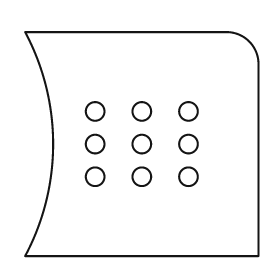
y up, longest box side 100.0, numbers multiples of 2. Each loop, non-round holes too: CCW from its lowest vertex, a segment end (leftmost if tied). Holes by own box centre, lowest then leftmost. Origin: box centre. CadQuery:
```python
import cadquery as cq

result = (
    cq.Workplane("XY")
    .moveTo(-50.0, -48.0)
    .lineTo(50.0, -48.0)
    .lineTo(50.0, 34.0)
    .threePointArc((46.0, 44.0), (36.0, 48.0))
    .lineTo(-50.0, 48.0)
    .threePointArc((-38.0, 0.0), (-50.0, -48.0))
    .close()
    .moveTo(-20.0, -14.0)
    .circle(4.0)
    .moveTo(0.0, -14.0)
    .circle(4.0)
    .moveTo(20.0, -14.0)
    .circle(4.0)
    .moveTo(-20.0, 0.0)
    .circle(4.0)
    .moveTo(0.0, 0.0)
    .circle(4.0)
    .moveTo(20.0, 0.0)
    .circle(4.0)
    .moveTo(-20.0, 14.0)
    .circle(4.0)
    .moveTo(0.0, 14.0)
    .circle(4.0)
    .moveTo(20.0, 14.0)
    .circle(4.0)
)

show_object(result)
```